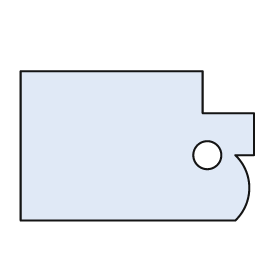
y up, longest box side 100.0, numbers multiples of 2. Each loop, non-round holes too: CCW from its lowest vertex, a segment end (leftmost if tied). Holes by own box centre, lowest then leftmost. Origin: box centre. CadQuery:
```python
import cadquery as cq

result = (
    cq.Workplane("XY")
    .moveTo(-50.0, -32.0)
    .lineTo(42.0, -32.0)
    .threePointArc((48.0, -18.0), (42.0, -4.0))
    .lineTo(50.0, -4.0)
    .lineTo(50.0, 14.0)
    .lineTo(28.0, 14.0)
    .lineTo(28.0, 32.0)
    .lineTo(-50.0, 32.0)
    .close()
    .moveTo(30.0, -4.0)
    .circle(6.0)
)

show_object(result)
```